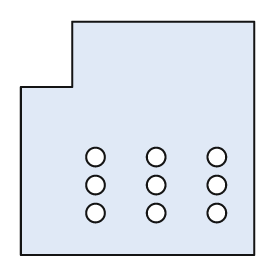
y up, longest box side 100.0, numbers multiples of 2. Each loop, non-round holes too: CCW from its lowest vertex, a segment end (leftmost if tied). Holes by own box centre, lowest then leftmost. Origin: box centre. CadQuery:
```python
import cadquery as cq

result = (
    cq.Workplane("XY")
    .moveTo(-50.0, -50.0)
    .lineTo(50.0, -50.0)
    .lineTo(50.0, 50.0)
    .lineTo(-28.0, 50.0)
    .lineTo(-28.0, 22.0)
    .lineTo(-50.0, 22.0)
    .close()
    .moveTo(-18.0, -32.0)
    .circle(4.0)
    .moveTo(8.0, -32.0)
    .circle(4.0)
    .moveTo(34.0, -32.0)
    .circle(4.0)
    .moveTo(-18.0, -20.0)
    .circle(4.0)
    .moveTo(8.0, -20.0)
    .circle(4.0)
    .moveTo(34.0, -20.0)
    .circle(4.0)
    .moveTo(-18.0, -8.0)
    .circle(4.0)
    .moveTo(8.0, -8.0)
    .circle(4.0)
    .moveTo(34.0, -8.0)
    .circle(4.0)
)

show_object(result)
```